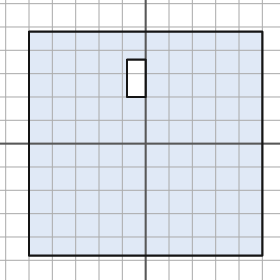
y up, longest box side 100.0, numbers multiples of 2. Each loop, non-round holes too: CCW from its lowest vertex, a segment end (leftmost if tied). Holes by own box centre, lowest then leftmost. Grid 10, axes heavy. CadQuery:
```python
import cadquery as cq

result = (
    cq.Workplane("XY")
    .moveTo(-50.0, -48.0)
    .lineTo(50.0, -48.0)
    .lineTo(50.0, 48.0)
    .lineTo(-50.0, 48.0)
    .close()
    .moveTo(-8.0, 20.0)
    .lineTo(0.0, 20.0)
    .lineTo(0.0, 36.0)
    .lineTo(-8.0, 36.0)
    .close()
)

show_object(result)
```